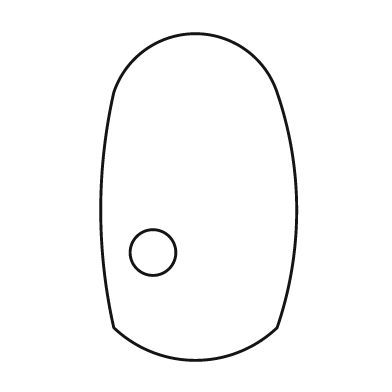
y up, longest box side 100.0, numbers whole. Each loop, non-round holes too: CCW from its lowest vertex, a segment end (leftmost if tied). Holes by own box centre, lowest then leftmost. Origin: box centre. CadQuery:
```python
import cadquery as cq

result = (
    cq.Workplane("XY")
    .moveTo(-26.0, -40.0)
    .threePointArc((-1.0, -50.0), (24.0, -40.0))
    .threePointArc((30.0, -4.0), (24.0, 32.0))
    .threePointArc((-1.0, 50.0), (-26.0, 32.0))
    .threePointArc((-30.0, -4.0), (-26.0, -40.0))
    .close()
    .moveTo(-14.0, -17.0)
    .circle(7.0)
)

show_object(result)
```